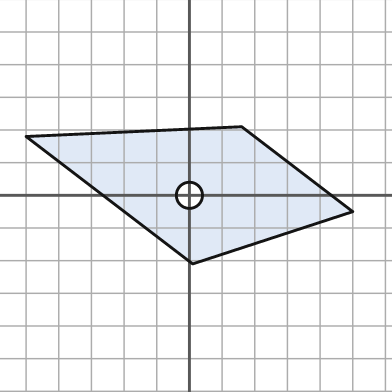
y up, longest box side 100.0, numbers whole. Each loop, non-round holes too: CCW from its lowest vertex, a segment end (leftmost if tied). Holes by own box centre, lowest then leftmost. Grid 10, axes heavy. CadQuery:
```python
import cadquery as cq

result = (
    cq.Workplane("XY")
    .moveTo(1.0, -21.0)
    .lineTo(50.0, -5.0)
    .lineTo(16.0, 21.0)
    .lineTo(-50.0, 18.0)
    .close()
    .moveTo(0.0, 0.0)
    .circle(4.0)
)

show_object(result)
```